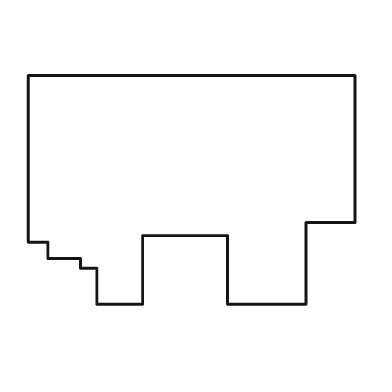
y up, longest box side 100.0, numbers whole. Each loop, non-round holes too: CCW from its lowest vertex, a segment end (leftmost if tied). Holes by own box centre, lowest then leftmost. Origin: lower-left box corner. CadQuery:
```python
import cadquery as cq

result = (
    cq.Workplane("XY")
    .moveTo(21.0, 0.0)
    .lineTo(35.0, 0.0)
    .lineTo(35.0, 21.0)
    .lineTo(61.0, 21.0)
    .lineTo(61.0, 0.0)
    .lineTo(85.0, 0.0)
    .lineTo(85.0, 25.0)
    .lineTo(100.0, 25.0)
    .lineTo(100.0, 70.0)
    .lineTo(0.0, 70.0)
    .lineTo(0.0, 19.0)
    .lineTo(6.0, 19.0)
    .lineTo(6.0, 14.0)
    .lineTo(16.0, 14.0)
    .lineTo(16.0, 11.0)
    .lineTo(21.0, 11.0)
    .close()
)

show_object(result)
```